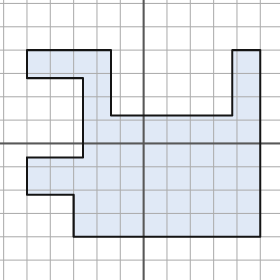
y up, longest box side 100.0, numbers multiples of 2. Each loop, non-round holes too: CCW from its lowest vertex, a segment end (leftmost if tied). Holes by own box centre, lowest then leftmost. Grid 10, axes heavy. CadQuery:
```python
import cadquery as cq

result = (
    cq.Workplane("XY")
    .moveTo(-30.0, -40.0)
    .lineTo(50.0, -40.0)
    .lineTo(50.0, 40.0)
    .lineTo(38.0, 40.0)
    .lineTo(38.0, 12.0)
    .lineTo(-14.0, 12.0)
    .lineTo(-14.0, 40.0)
    .lineTo(-50.0, 40.0)
    .lineTo(-50.0, 28.0)
    .lineTo(-26.0, 28.0)
    .lineTo(-26.0, -6.0)
    .lineTo(-50.0, -6.0)
    .lineTo(-50.0, -22.0)
    .lineTo(-30.0, -22.0)
    .close()
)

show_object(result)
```